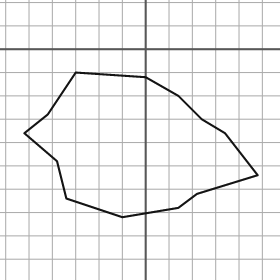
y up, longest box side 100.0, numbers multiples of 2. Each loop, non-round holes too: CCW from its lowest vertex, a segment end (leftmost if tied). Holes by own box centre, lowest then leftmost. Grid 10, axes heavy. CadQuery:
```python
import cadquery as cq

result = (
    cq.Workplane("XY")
    .moveTo(-10.0, -72.0)
    .lineTo(14.0, -68.0)
    .lineTo(22.0, -62.0)
    .lineTo(48.0, -54.0)
    .lineTo(34.0, -36.0)
    .lineTo(24.0, -30.0)
    .lineTo(14.0, -20.0)
    .lineTo(0.0, -12.0)
    .lineTo(-30.0, -10.0)
    .lineTo(-42.0, -28.0)
    .lineTo(-52.0, -36.0)
    .lineTo(-38.0, -48.0)
    .lineTo(-34.0, -64.0)
    .close()
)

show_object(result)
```